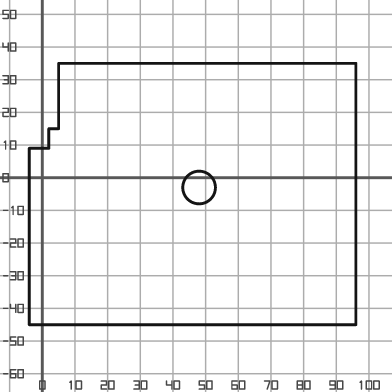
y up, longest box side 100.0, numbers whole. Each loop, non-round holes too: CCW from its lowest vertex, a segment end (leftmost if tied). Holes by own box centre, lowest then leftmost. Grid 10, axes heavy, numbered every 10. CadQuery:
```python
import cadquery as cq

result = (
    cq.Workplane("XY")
    .moveTo(-4.0, -45.0)
    .lineTo(96.0, -45.0)
    .lineTo(96.0, 35.0)
    .lineTo(5.0, 35.0)
    .lineTo(5.0, 15.0)
    .lineTo(2.0, 15.0)
    .lineTo(2.0, 9.0)
    .lineTo(-4.0, 9.0)
    .close()
    .moveTo(48.0, -3.0)
    .circle(5.0)
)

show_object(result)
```